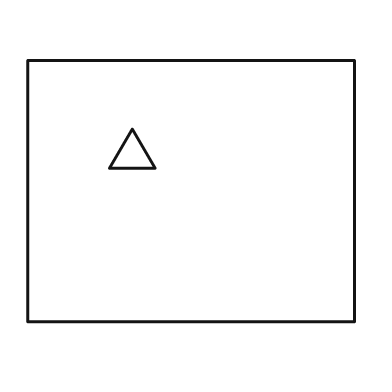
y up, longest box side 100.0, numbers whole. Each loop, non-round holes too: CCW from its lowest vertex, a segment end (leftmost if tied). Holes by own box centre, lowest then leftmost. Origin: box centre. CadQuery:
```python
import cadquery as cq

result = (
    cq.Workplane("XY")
    .moveTo(-50.0, -40.0)
    .lineTo(50.0, -40.0)
    .lineTo(50.0, 40.0)
    .lineTo(-50.0, 40.0)
    .close()
    .moveTo(-25.0, 7.0)
    .lineTo(-11.0, 7.0)
    .lineTo(-18.0, 19.0)
    .close()
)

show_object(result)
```